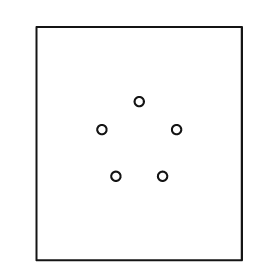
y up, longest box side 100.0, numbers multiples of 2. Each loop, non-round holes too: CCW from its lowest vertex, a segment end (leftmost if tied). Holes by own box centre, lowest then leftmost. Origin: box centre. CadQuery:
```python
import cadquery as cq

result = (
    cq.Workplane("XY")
    .moveTo(-44.0, -50.0)
    .lineTo(44.0, -50.0)
    .lineTo(44.0, 50.0)
    .lineTo(-44.0, 50.0)
    .close()
    .moveTo(-10.0, -14.0)
    .circle(2.0)
    .moveTo(10.0, -14.0)
    .circle(2.0)
    .moveTo(-16.0, 6.0)
    .circle(2.0)
    .moveTo(16.0, 6.0)
    .circle(2.0)
    .moveTo(0.0, 18.0)
    .circle(2.0)
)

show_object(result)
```